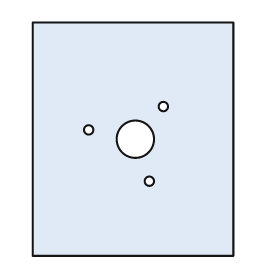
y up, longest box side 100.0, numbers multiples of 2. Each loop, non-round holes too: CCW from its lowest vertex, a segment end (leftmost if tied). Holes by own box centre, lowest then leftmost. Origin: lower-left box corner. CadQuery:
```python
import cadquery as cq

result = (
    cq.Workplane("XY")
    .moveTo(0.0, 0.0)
    .lineTo(86.0, 0.0)
    .lineTo(86.0, 100.0)
    .lineTo(0.0, 100.0)
    .close()
    .moveTo(50.0, 32.0)
    .circle(2.0)
    .moveTo(44.0, 50.0)
    .circle(8.0)
    .moveTo(24.0, 54.0)
    .circle(2.0)
    .moveTo(56.0, 64.0)
    .circle(2.0)
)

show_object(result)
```